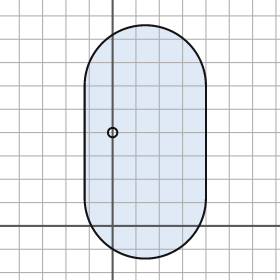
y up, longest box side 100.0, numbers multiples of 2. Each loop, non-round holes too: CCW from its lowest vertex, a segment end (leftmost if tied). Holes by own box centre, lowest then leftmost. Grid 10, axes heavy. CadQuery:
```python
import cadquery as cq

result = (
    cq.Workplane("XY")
    .moveTo(-12.0, 12.0)
    .threePointArc((14.0, -14.0), (40.0, 12.0))
    .lineTo(40.0, 60.0)
    .threePointArc((14.0, 86.0), (-12.0, 60.0))
    .close()
    .moveTo(0.0, 40.0)
    .circle(2.0)
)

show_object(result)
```